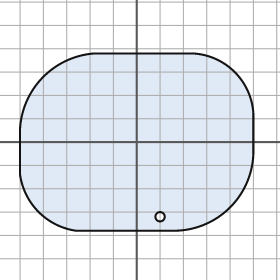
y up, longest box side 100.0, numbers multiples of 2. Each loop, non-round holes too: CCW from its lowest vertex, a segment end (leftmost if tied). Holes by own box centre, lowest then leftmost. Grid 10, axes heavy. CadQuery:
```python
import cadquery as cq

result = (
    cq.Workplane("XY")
    .moveTo(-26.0, -38.0)
    .lineTo(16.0, -38.0)
    .threePointArc((40.0, -28.0), (50.0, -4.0))
    .lineTo(50.0, 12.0)
    .threePointArc((42.0, 30.0), (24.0, 38.0))
    .lineTo(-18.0, 38.0)
    .threePointArc((-40.0, 28.0), (-50.0, 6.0))
    .lineTo(-50.0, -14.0)
    .threePointArc((-42.0, -30.0), (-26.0, -38.0))
    .close()
    .moveTo(10.0, -32.0)
    .circle(2.0)
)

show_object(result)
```